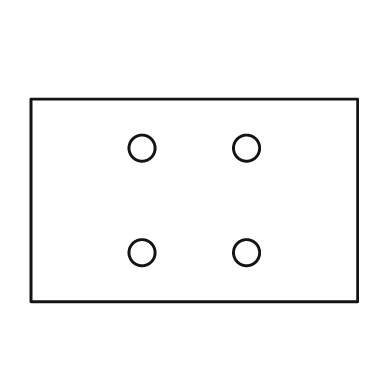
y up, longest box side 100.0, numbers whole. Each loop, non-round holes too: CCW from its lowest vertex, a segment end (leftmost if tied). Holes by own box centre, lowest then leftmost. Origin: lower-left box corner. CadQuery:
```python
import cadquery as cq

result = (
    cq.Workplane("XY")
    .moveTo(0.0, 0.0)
    .lineTo(100.0, 0.0)
    .lineTo(100.0, 62.0)
    .lineTo(0.0, 62.0)
    .close()
    .moveTo(34.0, 15.0)
    .circle(4.0)
    .moveTo(66.0, 15.0)
    .circle(4.0)
    .moveTo(34.0, 47.0)
    .circle(4.0)
    .moveTo(66.0, 47.0)
    .circle(4.0)
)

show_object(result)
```